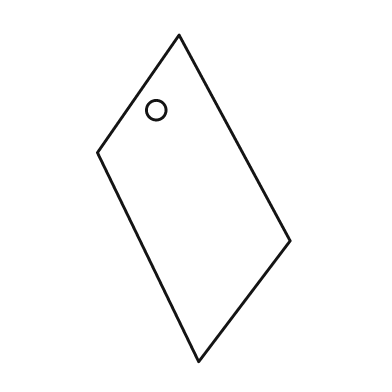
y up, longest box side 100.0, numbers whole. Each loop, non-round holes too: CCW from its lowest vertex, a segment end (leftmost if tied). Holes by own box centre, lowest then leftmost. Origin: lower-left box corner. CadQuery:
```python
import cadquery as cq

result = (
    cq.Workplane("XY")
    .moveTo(31.0, 0.0)
    .lineTo(59.0, 37.0)
    .lineTo(25.0, 100.0)
    .lineTo(0.0, 64.0)
    .close()
    .moveTo(18.0, 77.0)
    .circle(3.0)
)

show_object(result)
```